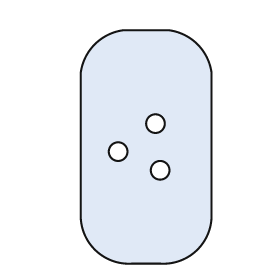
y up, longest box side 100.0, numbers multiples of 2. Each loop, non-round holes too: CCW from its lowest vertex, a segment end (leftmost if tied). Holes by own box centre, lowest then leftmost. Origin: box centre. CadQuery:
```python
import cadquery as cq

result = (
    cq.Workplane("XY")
    .moveTo(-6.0, -50.0)
    .lineTo(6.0, -50.0)
    .threePointArc((22.0, -44.0), (28.0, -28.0))
    .lineTo(28.0, 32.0)
    .threePointArc((22.0, 44.0), (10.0, 50.0))
    .lineTo(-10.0, 50.0)
    .threePointArc((-22.0, 44.0), (-28.0, 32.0))
    .lineTo(-28.0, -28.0)
    .threePointArc((-22.0, -44.0), (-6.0, -50.0))
    .close()
    .moveTo(6.0, -10.0)
    .circle(4.0)
    .moveTo(-12.0, -2.0)
    .circle(4.0)
    .moveTo(4.0, 10.0)
    .circle(4.0)
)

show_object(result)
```